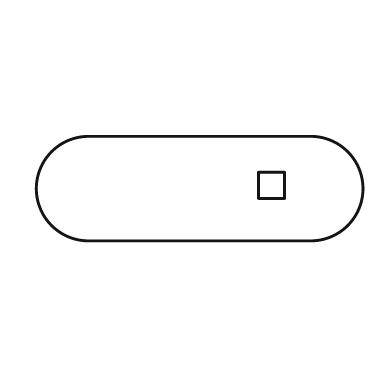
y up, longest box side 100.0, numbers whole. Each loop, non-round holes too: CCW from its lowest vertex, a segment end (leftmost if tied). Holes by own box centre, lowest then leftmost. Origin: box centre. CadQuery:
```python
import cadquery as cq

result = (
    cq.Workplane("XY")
    .moveTo(-34.0, -16.0)
    .lineTo(34.0, -16.0)
    .threePointArc((50.0, 0.0), (34.0, 16.0))
    .lineTo(-34.0, 16.0)
    .threePointArc((-50.0, 0.0), (-34.0, -16.0))
    .close()
    .moveTo(18.0, -3.0)
    .lineTo(26.0, -3.0)
    .lineTo(26.0, 5.0)
    .lineTo(18.0, 5.0)
    .close()
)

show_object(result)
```